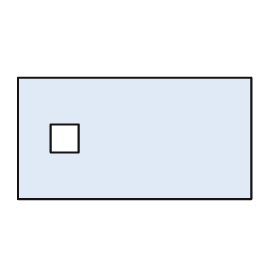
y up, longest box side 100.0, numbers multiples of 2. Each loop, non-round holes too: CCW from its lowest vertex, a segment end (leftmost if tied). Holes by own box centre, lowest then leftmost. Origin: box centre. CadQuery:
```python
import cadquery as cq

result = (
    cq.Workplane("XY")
    .moveTo(-50.0, -26.0)
    .lineTo(50.0, -26.0)
    .lineTo(50.0, 26.0)
    .lineTo(-50.0, 26.0)
    .close()
    .moveTo(-36.0, -6.0)
    .lineTo(-24.0, -6.0)
    .lineTo(-24.0, 6.0)
    .lineTo(-36.0, 6.0)
    .close()
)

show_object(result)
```